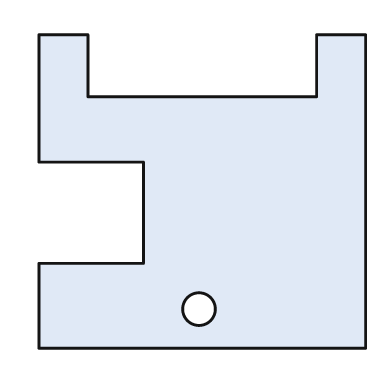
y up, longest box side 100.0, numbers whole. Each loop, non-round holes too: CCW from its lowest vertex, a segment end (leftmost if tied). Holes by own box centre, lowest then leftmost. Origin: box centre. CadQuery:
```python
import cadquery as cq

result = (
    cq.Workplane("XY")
    .moveTo(-50.0, -48.0)
    .lineTo(50.0, -48.0)
    .lineTo(50.0, 48.0)
    .lineTo(35.0, 48.0)
    .lineTo(35.0, 29.0)
    .lineTo(-35.0, 29.0)
    .lineTo(-35.0, 48.0)
    .lineTo(-50.0, 48.0)
    .lineTo(-50.0, 9.0)
    .lineTo(-18.0, 9.0)
    .lineTo(-18.0, -22.0)
    .lineTo(-50.0, -22.0)
    .close()
    .moveTo(-1.0, -36.0)
    .circle(5.0)
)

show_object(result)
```